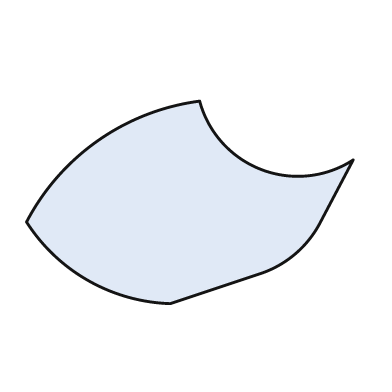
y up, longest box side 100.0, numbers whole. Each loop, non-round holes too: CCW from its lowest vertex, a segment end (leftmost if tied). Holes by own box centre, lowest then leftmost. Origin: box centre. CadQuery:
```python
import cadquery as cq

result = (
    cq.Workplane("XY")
    .moveTo(-6.0, -31.0)
    .lineTo(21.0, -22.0)
    .threePointArc((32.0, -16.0), (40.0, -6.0))
    .lineTo(50.0, 13.0)
    .threePointArc((22.0, 10.0), (3.0, 31.0))
    .threePointArc((-28.0, 19.0), (-50.0, -6.0))
    .threePointArc((-31.0, -24.0), (-6.0, -31.0))
    .close()
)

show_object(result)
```